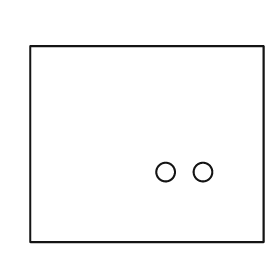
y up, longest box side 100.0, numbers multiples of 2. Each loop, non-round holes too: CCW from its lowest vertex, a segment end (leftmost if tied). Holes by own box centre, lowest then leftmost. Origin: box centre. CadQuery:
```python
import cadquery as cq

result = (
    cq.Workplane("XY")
    .moveTo(-50.0, -42.0)
    .lineTo(50.0, -42.0)
    .lineTo(50.0, 42.0)
    .lineTo(-50.0, 42.0)
    .close()
    .moveTo(8.0, -12.0)
    .circle(4.0)
    .moveTo(24.0, -12.0)
    .circle(4.0)
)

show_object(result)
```